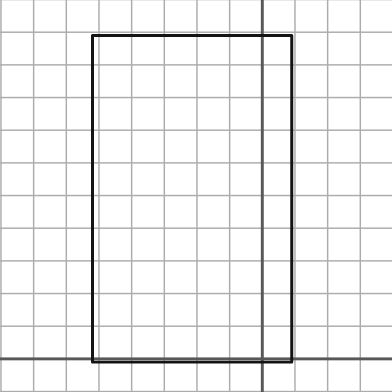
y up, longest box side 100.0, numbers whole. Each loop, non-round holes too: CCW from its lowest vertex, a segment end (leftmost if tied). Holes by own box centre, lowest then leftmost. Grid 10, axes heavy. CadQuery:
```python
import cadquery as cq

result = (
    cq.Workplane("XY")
    .moveTo(-52.0, -1.0)
    .lineTo(9.0, -1.0)
    .lineTo(9.0, 99.0)
    .lineTo(-52.0, 99.0)
    .close()
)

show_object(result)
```